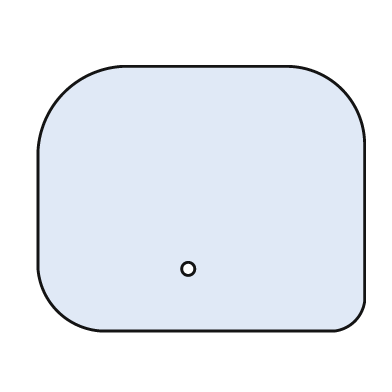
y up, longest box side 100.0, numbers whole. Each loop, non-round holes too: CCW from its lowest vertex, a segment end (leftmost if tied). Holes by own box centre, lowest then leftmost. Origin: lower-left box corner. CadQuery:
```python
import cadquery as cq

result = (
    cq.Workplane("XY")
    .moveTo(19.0, 0.0)
    .lineTo(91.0, 0.0)
    .threePointArc((97.0, 3.0), (100.0, 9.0))
    .lineTo(100.0, 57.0)
    .threePointArc((93.0, 74.0), (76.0, 81.0))
    .lineTo(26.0, 81.0)
    .threePointArc((8.0, 73.0), (0.0, 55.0))
    .lineTo(0.0, 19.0)
    .threePointArc((6.0, 6.0), (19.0, 0.0))
    .close()
    .moveTo(46.0, 19.0)
    .circle(2.0)
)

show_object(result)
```